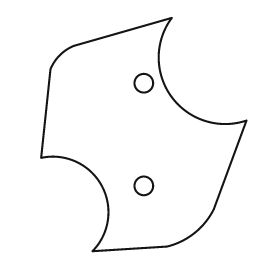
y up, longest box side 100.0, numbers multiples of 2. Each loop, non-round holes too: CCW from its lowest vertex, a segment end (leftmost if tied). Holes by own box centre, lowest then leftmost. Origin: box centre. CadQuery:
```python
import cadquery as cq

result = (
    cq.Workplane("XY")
    .moveTo(-22.0, -50.0)
    .lineTo(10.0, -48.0)
    .threePointArc((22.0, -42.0), (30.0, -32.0))
    .lineTo(44.0, 6.0)
    .threePointArc((12.0, 16.0), (12.0, 50.0))
    .lineTo(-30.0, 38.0)
    .threePointArc((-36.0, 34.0), (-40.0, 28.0))
    .lineTo(-44.0, -10.0)
    .threePointArc((-18.0, -22.0), (-22.0, -50.0))
    .close()
    .moveTo(0.0, -22.0)
    .circle(4.0)
    .moveTo(0.0, 22.0)
    .circle(4.0)
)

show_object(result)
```